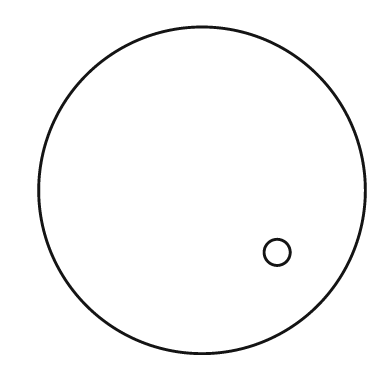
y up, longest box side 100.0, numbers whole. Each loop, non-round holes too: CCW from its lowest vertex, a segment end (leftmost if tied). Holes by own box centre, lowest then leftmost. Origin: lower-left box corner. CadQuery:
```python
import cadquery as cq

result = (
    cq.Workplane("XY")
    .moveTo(50.0, 50.0)
    .circle(50.0)
    .moveTo(73.0, 31.0)
    .circle(4.0)
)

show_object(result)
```